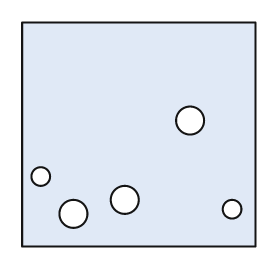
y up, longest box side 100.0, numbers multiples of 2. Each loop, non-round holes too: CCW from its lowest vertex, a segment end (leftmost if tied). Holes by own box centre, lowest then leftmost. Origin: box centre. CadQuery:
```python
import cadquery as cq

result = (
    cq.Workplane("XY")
    .moveTo(-50.0, -48.0)
    .lineTo(50.0, -48.0)
    .lineTo(50.0, 48.0)
    .lineTo(-50.0, 48.0)
    .close()
    .moveTo(-28.0, -34.0)
    .circle(6.0)
    .moveTo(40.0, -32.0)
    .circle(4.0)
    .moveTo(-6.0, -28.0)
    .circle(6.0)
    .moveTo(-42.0, -18.0)
    .circle(4.0)
    .moveTo(22.0, 6.0)
    .circle(6.0)
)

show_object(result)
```